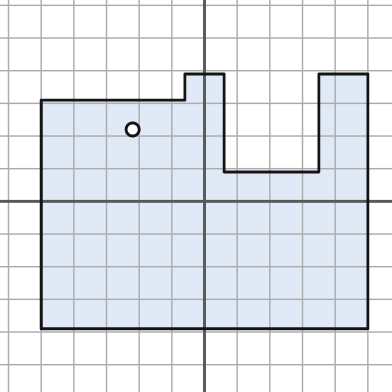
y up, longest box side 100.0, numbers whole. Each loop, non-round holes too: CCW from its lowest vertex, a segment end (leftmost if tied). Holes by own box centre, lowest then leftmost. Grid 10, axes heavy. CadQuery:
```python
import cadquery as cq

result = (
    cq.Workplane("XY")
    .moveTo(-50.0, -39.0)
    .lineTo(50.0, -39.0)
    .lineTo(50.0, 39.0)
    .lineTo(35.0, 39.0)
    .lineTo(35.0, 9.0)
    .lineTo(6.0, 9.0)
    .lineTo(6.0, 39.0)
    .lineTo(-6.0, 39.0)
    .lineTo(-6.0, 31.0)
    .lineTo(-50.0, 31.0)
    .close()
    .moveTo(-22.0, 22.0)
    .circle(2.0)
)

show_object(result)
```